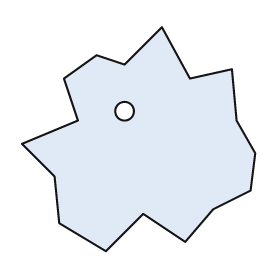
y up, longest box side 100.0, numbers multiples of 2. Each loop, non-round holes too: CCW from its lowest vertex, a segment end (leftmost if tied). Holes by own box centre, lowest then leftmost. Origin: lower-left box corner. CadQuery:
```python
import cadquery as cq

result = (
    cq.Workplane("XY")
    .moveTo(36.0, 0.0)
    .lineTo(52.0, 16.0)
    .lineTo(70.0, 4.0)
    .lineTo(82.0, 18.0)
    .lineTo(98.0, 26.0)
    .lineTo(100.0, 42.0)
    .lineTo(92.0, 56.0)
    .lineTo(90.0, 78.0)
    .lineTo(72.0, 74.0)
    .lineTo(60.0, 96.0)
    .lineTo(44.0, 80.0)
    .lineTo(32.0, 84.0)
    .lineTo(18.0, 74.0)
    .lineTo(24.0, 56.0)
    .lineTo(0.0, 46.0)
    .lineTo(14.0, 32.0)
    .lineTo(16.0, 12.0)
    .close()
    .moveTo(44.0, 60.0)
    .circle(4.0)
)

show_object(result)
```